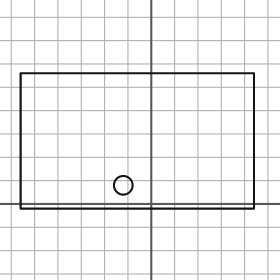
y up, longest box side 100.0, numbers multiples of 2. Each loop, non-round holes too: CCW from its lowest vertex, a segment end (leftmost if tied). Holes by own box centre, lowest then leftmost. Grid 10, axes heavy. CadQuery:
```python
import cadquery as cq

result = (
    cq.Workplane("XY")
    .moveTo(-56.0, -2.0)
    .lineTo(44.0, -2.0)
    .lineTo(44.0, 56.0)
    .lineTo(-56.0, 56.0)
    .close()
    .moveTo(-12.0, 8.0)
    .circle(4.0)
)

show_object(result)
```